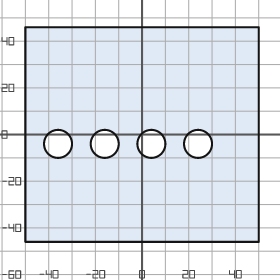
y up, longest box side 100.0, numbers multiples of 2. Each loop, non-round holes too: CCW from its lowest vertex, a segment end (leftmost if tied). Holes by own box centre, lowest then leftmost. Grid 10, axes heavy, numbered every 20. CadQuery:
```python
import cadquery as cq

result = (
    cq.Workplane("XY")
    .moveTo(-50.0, -46.0)
    .lineTo(50.0, -46.0)
    .lineTo(50.0, 46.0)
    .lineTo(-50.0, 46.0)
    .close()
    .moveTo(-36.0, -4.0)
    .circle(6.0)
    .moveTo(-16.0, -4.0)
    .circle(6.0)
    .moveTo(4.0, -4.0)
    .circle(6.0)
    .moveTo(24.0, -4.0)
    .circle(6.0)
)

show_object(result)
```